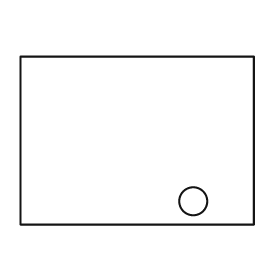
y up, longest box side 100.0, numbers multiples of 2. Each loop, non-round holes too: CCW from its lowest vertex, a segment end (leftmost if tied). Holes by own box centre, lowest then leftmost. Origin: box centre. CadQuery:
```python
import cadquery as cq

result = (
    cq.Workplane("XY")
    .moveTo(-50.0, -36.0)
    .lineTo(50.0, -36.0)
    .lineTo(50.0, 36.0)
    .lineTo(-50.0, 36.0)
    .close()
    .moveTo(24.0, -26.0)
    .circle(6.0)
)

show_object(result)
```